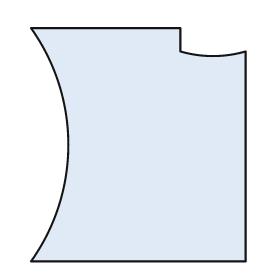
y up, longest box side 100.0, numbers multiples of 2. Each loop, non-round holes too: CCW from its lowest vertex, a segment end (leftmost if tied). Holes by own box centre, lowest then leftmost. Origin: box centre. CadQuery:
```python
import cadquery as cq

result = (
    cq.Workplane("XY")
    .moveTo(-46.0, -50.0)
    .lineTo(46.0, -50.0)
    .lineTo(46.0, 40.0)
    .threePointArc((32.0, 38.0), (18.0, 40.0))
    .lineTo(18.0, 50.0)
    .lineTo(-46.0, 50.0)
    .threePointArc((-30.0, 0.0), (-46.0, -50.0))
    .close()
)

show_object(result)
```